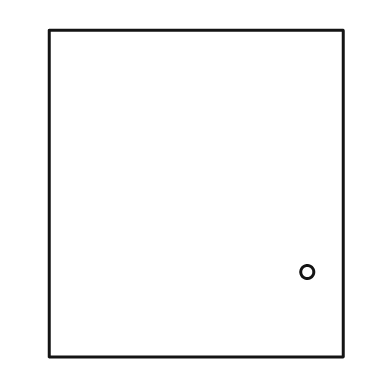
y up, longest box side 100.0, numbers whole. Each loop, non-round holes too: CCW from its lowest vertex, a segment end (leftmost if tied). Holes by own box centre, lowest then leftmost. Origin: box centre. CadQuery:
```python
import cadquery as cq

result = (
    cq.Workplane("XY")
    .moveTo(-45.0, -50.0)
    .lineTo(45.0, -50.0)
    .lineTo(45.0, 50.0)
    .lineTo(-45.0, 50.0)
    .close()
    .moveTo(34.0, -24.0)
    .circle(2.0)
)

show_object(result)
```